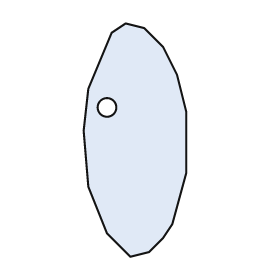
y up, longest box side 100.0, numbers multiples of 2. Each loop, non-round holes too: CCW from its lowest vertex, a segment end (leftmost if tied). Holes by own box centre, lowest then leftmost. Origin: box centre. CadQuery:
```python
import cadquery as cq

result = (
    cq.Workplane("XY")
    .moveTo(-2.0, -50.0)
    .lineTo(6.0, -48.0)
    .lineTo(12.0, -42.0)
    .lineTo(16.0, -36.0)
    .lineTo(22.0, -14.0)
    .lineTo(22.0, 12.0)
    .lineTo(18.0, 28.0)
    .lineTo(12.0, 40.0)
    .lineTo(4.0, 48.0)
    .lineTo(-4.0, 50.0)
    .lineTo(-10.0, 46.0)
    .lineTo(-20.0, 22.0)
    .lineTo(-22.0, 4.0)
    .lineTo(-20.0, -20.0)
    .lineTo(-12.0, -40.0)
    .close()
    .moveTo(-12.0, 14.0)
    .circle(4.0)
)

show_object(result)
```